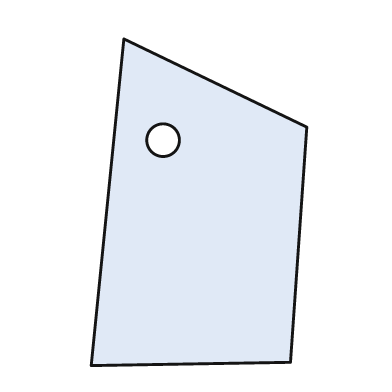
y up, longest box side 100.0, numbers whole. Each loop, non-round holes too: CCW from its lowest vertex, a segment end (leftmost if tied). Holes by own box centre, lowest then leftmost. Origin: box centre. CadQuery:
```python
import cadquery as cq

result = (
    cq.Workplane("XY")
    .moveTo(-33.0, -50.0)
    .lineTo(28.0, -49.0)
    .lineTo(33.0, 23.0)
    .lineTo(-23.0, 50.0)
    .close()
    .moveTo(-11.0, 19.0)
    .circle(5.0)
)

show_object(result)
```